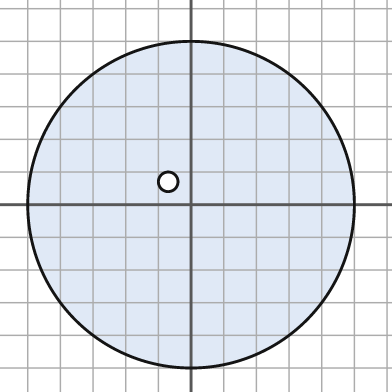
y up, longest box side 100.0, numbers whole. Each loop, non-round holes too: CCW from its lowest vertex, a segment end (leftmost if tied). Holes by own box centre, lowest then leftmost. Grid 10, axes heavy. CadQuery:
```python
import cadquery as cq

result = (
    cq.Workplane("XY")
    .moveTo(0.0, 0.0)
    .circle(50.0)
    .moveTo(-7.0, 7.0)
    .circle(3.0)
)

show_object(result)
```